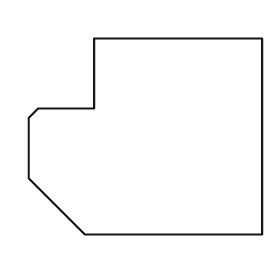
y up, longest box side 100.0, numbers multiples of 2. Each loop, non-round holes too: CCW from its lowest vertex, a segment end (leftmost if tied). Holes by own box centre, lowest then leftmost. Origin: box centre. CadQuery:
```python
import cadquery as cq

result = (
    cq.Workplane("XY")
    .moveTo(-26.0, -42.0)
    .lineTo(50.0, -42.0)
    .lineTo(50.0, 42.0)
    .lineTo(-22.0, 42.0)
    .lineTo(-22.0, 12.0)
    .lineTo(-46.0, 12.0)
    .lineTo(-50.0, 8.0)
    .lineTo(-50.0, -18.0)
    .close()
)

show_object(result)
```